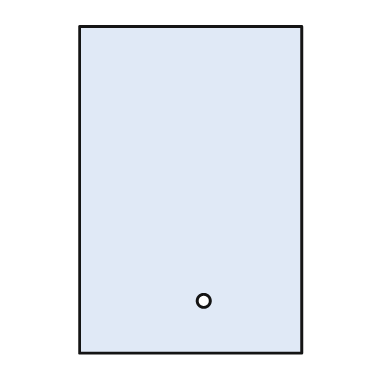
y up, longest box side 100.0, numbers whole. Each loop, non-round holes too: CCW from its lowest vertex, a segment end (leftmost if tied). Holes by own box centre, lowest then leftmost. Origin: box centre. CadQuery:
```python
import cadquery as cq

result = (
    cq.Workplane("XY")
    .moveTo(-34.0, -50.0)
    .lineTo(34.0, -50.0)
    .lineTo(34.0, 50.0)
    .lineTo(-34.0, 50.0)
    .close()
    .moveTo(4.0, -34.0)
    .circle(2.0)
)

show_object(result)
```